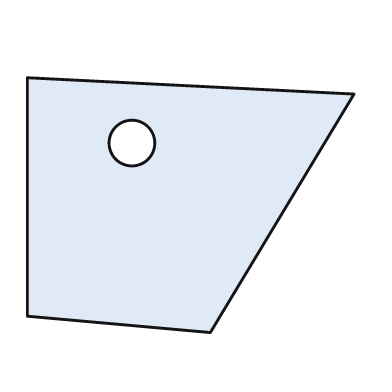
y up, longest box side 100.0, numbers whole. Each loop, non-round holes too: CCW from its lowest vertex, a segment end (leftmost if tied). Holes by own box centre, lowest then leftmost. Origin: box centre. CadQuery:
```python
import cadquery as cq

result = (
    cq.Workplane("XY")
    .moveTo(6.0, -39.0)
    .lineTo(50.0, 34.0)
    .lineTo(-50.0, 39.0)
    .lineTo(-50.0, -34.0)
    .close()
    .moveTo(-18.0, 19.0)
    .circle(7.0)
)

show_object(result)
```